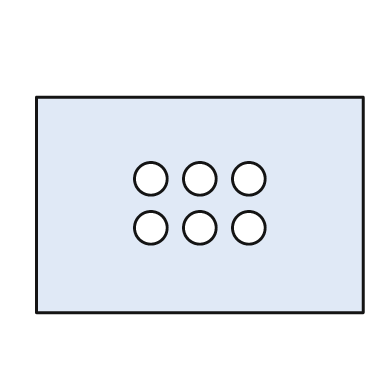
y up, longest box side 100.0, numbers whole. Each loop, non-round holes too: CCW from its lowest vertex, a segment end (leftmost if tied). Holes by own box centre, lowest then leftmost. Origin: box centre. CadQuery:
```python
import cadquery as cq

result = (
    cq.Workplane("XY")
    .moveTo(-50.0, -33.0)
    .lineTo(50.0, -33.0)
    .lineTo(50.0, 33.0)
    .lineTo(-50.0, 33.0)
    .close()
    .moveTo(-15.0, -7.0)
    .circle(5.0)
    .moveTo(0.0, -7.0)
    .circle(5.0)
    .moveTo(15.0, -7.0)
    .circle(5.0)
    .moveTo(-15.0, 8.0)
    .circle(5.0)
    .moveTo(0.0, 8.0)
    .circle(5.0)
    .moveTo(15.0, 8.0)
    .circle(5.0)
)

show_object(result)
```